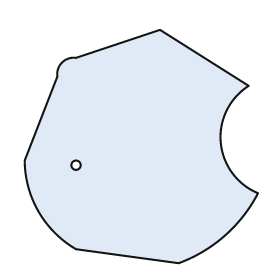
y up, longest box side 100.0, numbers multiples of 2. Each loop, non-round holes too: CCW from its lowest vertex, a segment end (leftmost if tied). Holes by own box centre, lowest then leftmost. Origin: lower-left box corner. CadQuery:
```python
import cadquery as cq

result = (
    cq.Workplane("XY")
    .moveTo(66.0, 0.0)
    .threePointArc((86.0, 12.0), (100.0, 30.0))
    .threePointArc((84.0, 52.0), (96.0, 76.0))
    .lineTo(58.0, 100.0)
    .lineTo(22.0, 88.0)
    .threePointArc((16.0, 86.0), (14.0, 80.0))
    .lineTo(0.0, 44.0)
    .threePointArc((6.0, 22.0), (22.0, 6.0))
    .close()
    .moveTo(22.0, 42.0)
    .circle(2.0)
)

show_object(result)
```